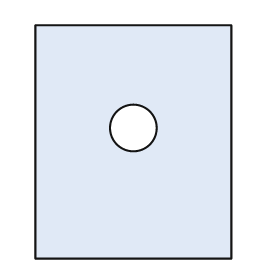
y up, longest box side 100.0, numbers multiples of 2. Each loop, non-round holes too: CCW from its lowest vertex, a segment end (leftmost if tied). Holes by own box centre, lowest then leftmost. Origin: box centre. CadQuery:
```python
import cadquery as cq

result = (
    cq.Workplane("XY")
    .moveTo(-42.0, -50.0)
    .lineTo(42.0, -50.0)
    .lineTo(42.0, 50.0)
    .lineTo(-42.0, 50.0)
    .close()
    .moveTo(0.0, 6.0)
    .circle(10.0)
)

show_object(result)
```